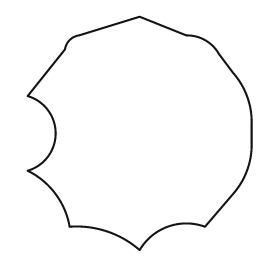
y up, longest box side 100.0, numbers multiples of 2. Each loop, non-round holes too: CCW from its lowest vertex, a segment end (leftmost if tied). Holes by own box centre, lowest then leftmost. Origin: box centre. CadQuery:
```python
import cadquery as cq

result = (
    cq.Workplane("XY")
    .moveTo(0.0, -50.0)
    .threePointArc((12.0, -40.0), (28.0, -40.0))
    .lineTo(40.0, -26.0)
    .threePointArc((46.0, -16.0), (48.0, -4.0))
    .lineTo(48.0, 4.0)
    .threePointArc((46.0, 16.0), (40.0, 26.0))
    .lineTo(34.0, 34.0)
    .threePointArc((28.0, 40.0), (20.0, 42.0))
    .lineTo(0.0, 50.0)
    .lineTo(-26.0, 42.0)
    .threePointArc((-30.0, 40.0), (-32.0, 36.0))
    .lineTo(-48.0, 16.0)
    .threePointArc((-36.0, 0.0), (-48.0, -16.0))
    .threePointArc((-36.0, -26.0), (-30.0, -40.0))
    .threePointArc((-14.0, -42.0), (0.0, -50.0))
    .close()
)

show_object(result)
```